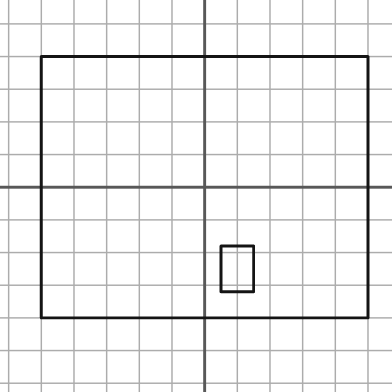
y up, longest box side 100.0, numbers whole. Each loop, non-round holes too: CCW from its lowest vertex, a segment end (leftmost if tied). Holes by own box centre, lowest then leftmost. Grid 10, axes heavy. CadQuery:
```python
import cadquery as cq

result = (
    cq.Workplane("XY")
    .moveTo(-50.0, -40.0)
    .lineTo(50.0, -40.0)
    .lineTo(50.0, 40.0)
    .lineTo(-50.0, 40.0)
    .close()
    .moveTo(5.0, -32.0)
    .lineTo(15.0, -32.0)
    .lineTo(15.0, -18.0)
    .lineTo(5.0, -18.0)
    .close()
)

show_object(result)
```